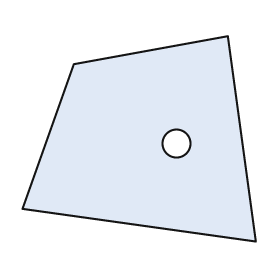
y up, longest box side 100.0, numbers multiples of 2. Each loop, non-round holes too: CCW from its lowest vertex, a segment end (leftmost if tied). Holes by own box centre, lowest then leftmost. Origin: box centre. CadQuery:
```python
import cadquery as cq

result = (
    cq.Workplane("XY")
    .moveTo(50.0, -44.0)
    .lineTo(38.0, 44.0)
    .lineTo(-28.0, 32.0)
    .lineTo(-50.0, -30.0)
    .close()
    .moveTo(16.0, -2.0)
    .circle(6.0)
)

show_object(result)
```